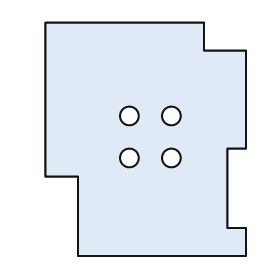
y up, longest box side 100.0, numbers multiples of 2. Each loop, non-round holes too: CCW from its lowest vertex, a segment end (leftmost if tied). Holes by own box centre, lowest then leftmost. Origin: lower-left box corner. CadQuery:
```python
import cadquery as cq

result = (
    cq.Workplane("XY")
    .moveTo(14.0, 0.0)
    .lineTo(86.0, 0.0)
    .lineTo(86.0, 12.0)
    .lineTo(78.0, 12.0)
    .lineTo(78.0, 46.0)
    .lineTo(86.0, 46.0)
    .lineTo(86.0, 88.0)
    .lineTo(68.0, 88.0)
    .lineTo(68.0, 100.0)
    .lineTo(0.0, 100.0)
    .lineTo(0.0, 34.0)
    .lineTo(14.0, 34.0)
    .close()
    .moveTo(36.0, 42.0)
    .circle(4.0)
    .moveTo(54.0, 42.0)
    .circle(4.0)
    .moveTo(36.0, 60.0)
    .circle(4.0)
    .moveTo(54.0, 60.0)
    .circle(4.0)
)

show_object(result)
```